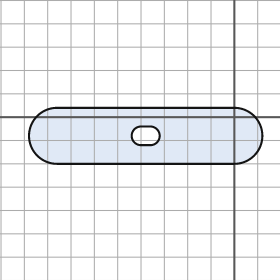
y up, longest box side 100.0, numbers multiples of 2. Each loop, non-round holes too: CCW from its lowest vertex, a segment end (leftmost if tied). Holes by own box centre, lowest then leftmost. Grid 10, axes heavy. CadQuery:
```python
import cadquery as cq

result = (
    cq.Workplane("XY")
    .moveTo(-76.0, -20.0)
    .lineTo(0.0, -20.0)
    .threePointArc((12.0, -8.0), (0.0, 4.0))
    .lineTo(-76.0, 4.0)
    .threePointArc((-88.0, -8.0), (-76.0, -20.0))
    .close()
    .moveTo(-40.0, -12.0)
    .lineTo(-36.0, -12.0)
    .threePointArc((-32.0, -8.0), (-36.0, -4.0))
    .lineTo(-40.0, -4.0)
    .threePointArc((-44.0, -8.0), (-40.0, -12.0))
    .close()
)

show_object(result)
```